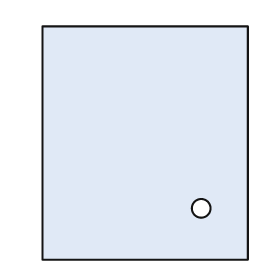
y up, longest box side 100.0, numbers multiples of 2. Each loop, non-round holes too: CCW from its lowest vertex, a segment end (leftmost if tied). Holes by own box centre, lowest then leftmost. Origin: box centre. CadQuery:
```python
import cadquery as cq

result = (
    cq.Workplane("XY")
    .moveTo(-44.0, -50.0)
    .lineTo(44.0, -50.0)
    .lineTo(44.0, 50.0)
    .lineTo(-44.0, 50.0)
    .close()
    .moveTo(24.0, -28.0)
    .circle(4.0)
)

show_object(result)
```